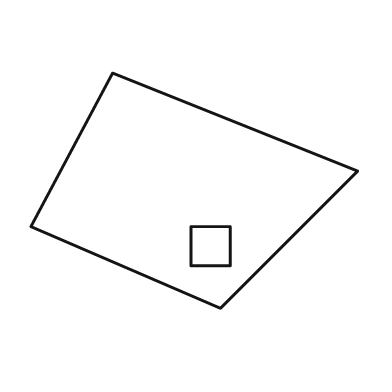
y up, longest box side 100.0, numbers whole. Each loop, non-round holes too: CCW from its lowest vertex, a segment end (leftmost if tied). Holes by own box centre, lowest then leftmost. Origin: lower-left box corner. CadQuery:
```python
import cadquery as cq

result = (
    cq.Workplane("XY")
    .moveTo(58.0, 0.0)
    .lineTo(100.0, 42.0)
    .lineTo(25.0, 72.0)
    .lineTo(0.0, 25.0)
    .close()
    .moveTo(49.0, 13.0)
    .lineTo(61.0, 13.0)
    .lineTo(61.0, 25.0)
    .lineTo(49.0, 25.0)
    .close()
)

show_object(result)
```